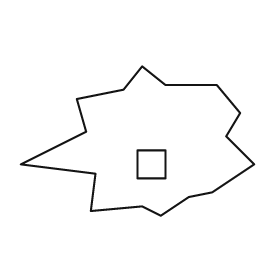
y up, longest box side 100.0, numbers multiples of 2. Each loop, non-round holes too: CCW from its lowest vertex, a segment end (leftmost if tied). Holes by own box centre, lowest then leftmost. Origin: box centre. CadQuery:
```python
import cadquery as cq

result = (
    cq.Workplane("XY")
    .moveTo(10.0, -32.0)
    .lineTo(22.0, -24.0)
    .lineTo(32.0, -22.0)
    .lineTo(50.0, -10.0)
    .lineTo(38.0, 2.0)
    .lineTo(44.0, 12.0)
    .lineTo(34.0, 24.0)
    .lineTo(12.0, 24.0)
    .lineTo(2.0, 32.0)
    .lineTo(-6.0, 22.0)
    .lineTo(-26.0, 18.0)
    .lineTo(-22.0, 4.0)
    .lineTo(-50.0, -10.0)
    .lineTo(-18.0, -14.0)
    .lineTo(-20.0, -30.0)
    .lineTo(2.0, -28.0)
    .close()
    .moveTo(0.0, -16.0)
    .lineTo(12.0, -16.0)
    .lineTo(12.0, -4.0)
    .lineTo(0.0, -4.0)
    .close()
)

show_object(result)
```